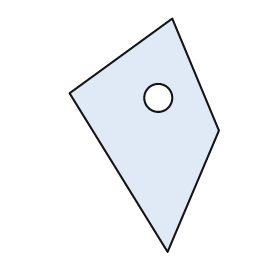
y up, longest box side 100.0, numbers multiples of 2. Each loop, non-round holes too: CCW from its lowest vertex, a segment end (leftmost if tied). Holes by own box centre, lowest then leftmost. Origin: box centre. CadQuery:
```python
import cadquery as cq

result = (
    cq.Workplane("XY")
    .moveTo(10.0, -50.0)
    .lineTo(32.0, 2.0)
    .lineTo(12.0, 50.0)
    .lineTo(-32.0, 18.0)
    .close()
    .moveTo(6.0, 16.0)
    .circle(6.0)
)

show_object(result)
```